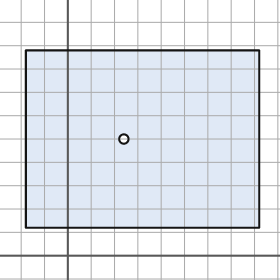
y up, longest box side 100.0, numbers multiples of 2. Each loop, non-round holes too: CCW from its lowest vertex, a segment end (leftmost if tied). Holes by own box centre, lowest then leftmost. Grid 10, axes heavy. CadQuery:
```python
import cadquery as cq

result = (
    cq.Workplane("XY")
    .moveTo(-18.0, 12.0)
    .lineTo(82.0, 12.0)
    .lineTo(82.0, 88.0)
    .lineTo(-18.0, 88.0)
    .close()
    .moveTo(24.0, 50.0)
    .circle(2.0)
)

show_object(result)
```